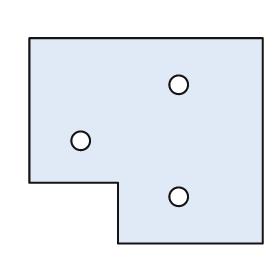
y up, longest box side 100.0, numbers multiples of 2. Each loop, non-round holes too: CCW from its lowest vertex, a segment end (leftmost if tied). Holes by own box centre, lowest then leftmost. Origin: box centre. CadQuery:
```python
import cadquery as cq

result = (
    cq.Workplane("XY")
    .moveTo(-12.0, -44.0)
    .lineTo(50.0, -44.0)
    .lineTo(50.0, 44.0)
    .lineTo(-50.0, 44.0)
    .lineTo(-50.0, -18.0)
    .lineTo(-12.0, -18.0)
    .close()
    .moveTo(14.0, -24.0)
    .circle(4.0)
    .moveTo(-28.0, 0.0)
    .circle(4.0)
    .moveTo(14.0, 24.0)
    .circle(4.0)
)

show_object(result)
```